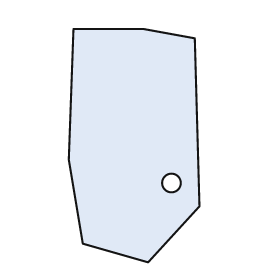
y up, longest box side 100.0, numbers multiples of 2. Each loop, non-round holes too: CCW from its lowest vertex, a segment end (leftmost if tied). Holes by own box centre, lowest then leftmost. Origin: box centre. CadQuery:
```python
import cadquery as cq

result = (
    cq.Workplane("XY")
    .moveTo(6.0, -50.0)
    .lineTo(28.0, -26.0)
    .lineTo(26.0, 46.0)
    .lineTo(4.0, 50.0)
    .lineTo(-26.0, 50.0)
    .lineTo(-28.0, -6.0)
    .lineTo(-22.0, -42.0)
    .close()
    .moveTo(16.0, -16.0)
    .circle(4.0)
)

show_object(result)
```